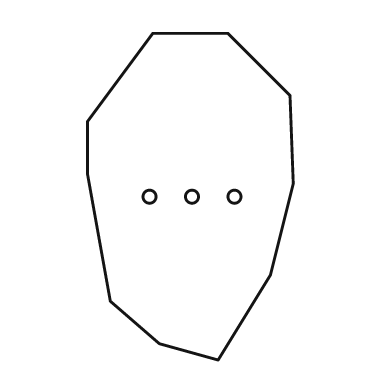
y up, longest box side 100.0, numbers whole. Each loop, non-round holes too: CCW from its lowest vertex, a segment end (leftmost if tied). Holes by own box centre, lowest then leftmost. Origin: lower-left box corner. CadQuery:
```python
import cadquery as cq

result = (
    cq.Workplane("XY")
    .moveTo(40.0, 0.0)
    .lineTo(56.0, 26.0)
    .lineTo(63.0, 54.0)
    .lineTo(62.0, 81.0)
    .lineTo(43.0, 100.0)
    .lineTo(20.0, 100.0)
    .lineTo(0.0, 73.0)
    .lineTo(0.0, 57.0)
    .lineTo(7.0, 18.0)
    .lineTo(22.0, 5.0)
    .close()
    .moveTo(19.0, 50.0)
    .circle(2.0)
    .moveTo(32.0, 50.0)
    .circle(2.0)
    .moveTo(45.0, 50.0)
    .circle(2.0)
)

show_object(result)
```